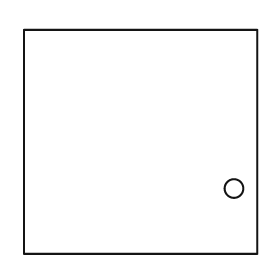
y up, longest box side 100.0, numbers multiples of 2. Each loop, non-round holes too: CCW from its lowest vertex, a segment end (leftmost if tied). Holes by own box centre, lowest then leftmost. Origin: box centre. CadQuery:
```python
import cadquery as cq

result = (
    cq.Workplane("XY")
    .moveTo(-50.0, -48.0)
    .lineTo(50.0, -48.0)
    .lineTo(50.0, 48.0)
    .lineTo(-50.0, 48.0)
    .close()
    .moveTo(40.0, -20.0)
    .circle(4.0)
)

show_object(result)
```